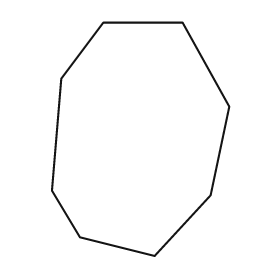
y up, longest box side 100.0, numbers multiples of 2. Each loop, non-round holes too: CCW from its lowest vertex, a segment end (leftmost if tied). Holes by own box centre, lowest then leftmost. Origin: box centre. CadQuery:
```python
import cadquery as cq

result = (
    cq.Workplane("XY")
    .moveTo(6.0, -50.0)
    .lineTo(30.0, -24.0)
    .lineTo(38.0, 14.0)
    .lineTo(18.0, 50.0)
    .lineTo(-16.0, 50.0)
    .lineTo(-34.0, 26.0)
    .lineTo(-38.0, -22.0)
    .lineTo(-26.0, -42.0)
    .close()
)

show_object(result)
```